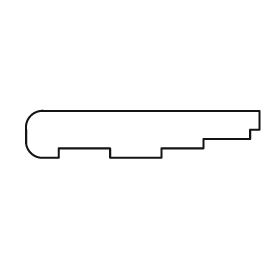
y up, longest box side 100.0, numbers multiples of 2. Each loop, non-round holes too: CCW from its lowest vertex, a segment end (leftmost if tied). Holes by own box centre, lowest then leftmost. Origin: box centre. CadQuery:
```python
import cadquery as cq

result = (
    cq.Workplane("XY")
    .moveTo(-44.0, -10.0)
    .lineTo(-36.0, -10.0)
    .lineTo(-36.0, -6.0)
    .lineTo(-14.0, -6.0)
    .lineTo(-14.0, -10.0)
    .lineTo(8.0, -10.0)
    .lineTo(8.0, -6.0)
    .lineTo(26.0, -6.0)
    .lineTo(26.0, -2.0)
    .lineTo(46.0, -2.0)
    .lineTo(46.0, 2.0)
    .lineTo(50.0, 2.0)
    .lineTo(50.0, 10.0)
    .lineTo(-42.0, 10.0)
    .threePointArc((-48.0, 8.0), (-50.0, 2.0))
    .lineTo(-50.0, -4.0)
    .threePointArc((-48.0, -8.0), (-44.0, -10.0))
    .close()
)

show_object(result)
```